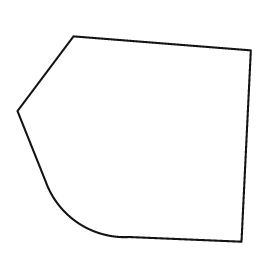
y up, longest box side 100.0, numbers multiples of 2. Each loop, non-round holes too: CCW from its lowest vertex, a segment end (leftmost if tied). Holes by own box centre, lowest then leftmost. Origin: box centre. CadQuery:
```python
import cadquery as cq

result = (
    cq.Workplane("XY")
    .moveTo(46.0, -44.0)
    .lineTo(50.0, 38.0)
    .lineTo(-26.0, 44.0)
    .lineTo(-50.0, 12.0)
    .lineTo(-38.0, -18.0)
    .threePointArc((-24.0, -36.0), (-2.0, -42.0))
    .close()
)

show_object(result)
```